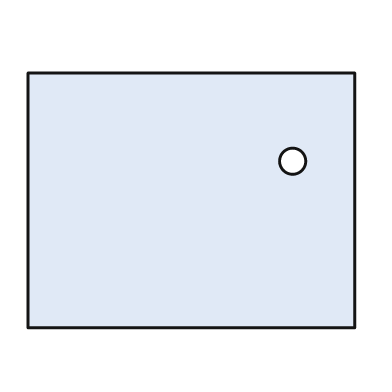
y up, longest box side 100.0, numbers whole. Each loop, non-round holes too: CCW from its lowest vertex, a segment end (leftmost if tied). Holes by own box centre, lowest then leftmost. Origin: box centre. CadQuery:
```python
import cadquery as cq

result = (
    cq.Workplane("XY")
    .moveTo(-50.0, -39.0)
    .lineTo(50.0, -39.0)
    .lineTo(50.0, 39.0)
    .lineTo(-50.0, 39.0)
    .close()
    .moveTo(31.0, 12.0)
    .circle(4.0)
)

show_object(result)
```